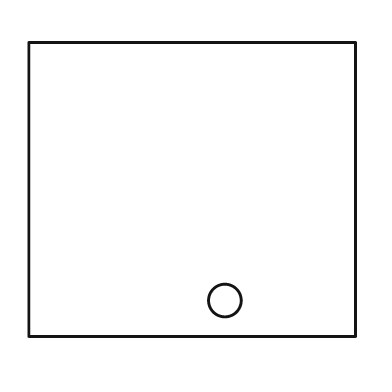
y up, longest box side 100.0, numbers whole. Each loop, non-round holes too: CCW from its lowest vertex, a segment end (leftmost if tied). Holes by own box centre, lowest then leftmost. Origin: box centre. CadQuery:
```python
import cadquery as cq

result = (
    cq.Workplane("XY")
    .moveTo(-50.0, -45.0)
    .lineTo(50.0, -45.0)
    .lineTo(50.0, 45.0)
    .lineTo(-50.0, 45.0)
    .close()
    .moveTo(10.0, -34.0)
    .circle(5.0)
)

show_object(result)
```